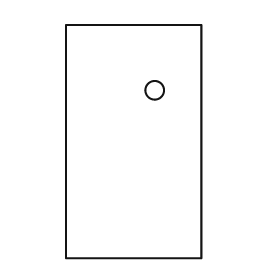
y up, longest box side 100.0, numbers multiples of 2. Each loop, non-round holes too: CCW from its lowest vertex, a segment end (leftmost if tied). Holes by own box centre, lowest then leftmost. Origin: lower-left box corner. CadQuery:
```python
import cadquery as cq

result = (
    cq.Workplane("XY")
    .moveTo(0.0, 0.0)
    .lineTo(58.0, 0.0)
    .lineTo(58.0, 100.0)
    .lineTo(0.0, 100.0)
    .close()
    .moveTo(38.0, 72.0)
    .circle(4.0)
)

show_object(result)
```